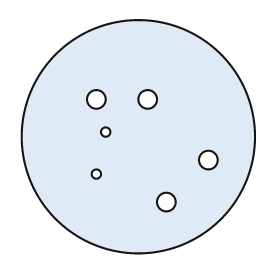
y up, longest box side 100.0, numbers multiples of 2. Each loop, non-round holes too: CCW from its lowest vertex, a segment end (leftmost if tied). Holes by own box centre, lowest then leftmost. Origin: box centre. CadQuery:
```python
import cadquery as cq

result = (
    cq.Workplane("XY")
    .moveTo(0.0, 0.0)
    .circle(50.0)
    .moveTo(12.0, -28.0)
    .circle(4.0)
    .moveTo(-18.0, -16.0)
    .circle(2.0)
    .moveTo(30.0, -10.0)
    .circle(4.0)
    .moveTo(-14.0, 2.0)
    .circle(2.0)
    .moveTo(-18.0, 16.0)
    .circle(4.0)
    .moveTo(4.0, 16.0)
    .circle(4.0)
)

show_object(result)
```